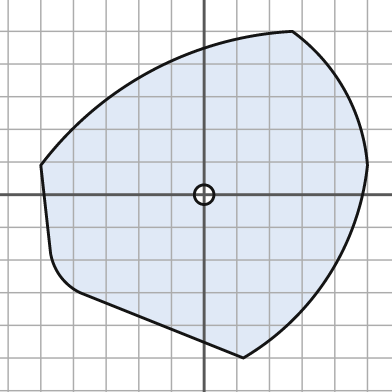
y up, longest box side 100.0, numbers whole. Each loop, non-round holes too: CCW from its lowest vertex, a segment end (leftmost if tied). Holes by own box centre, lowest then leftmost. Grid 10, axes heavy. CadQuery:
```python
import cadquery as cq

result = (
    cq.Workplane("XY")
    .moveTo(12.0, -50.0)
    .threePointArc((38.0, -25.0), (50.0, 9.0))
    .threePointArc((43.0, 32.0), (27.0, 50.0))
    .threePointArc((-16.0, 38.0), (-50.0, 9.0))
    .lineTo(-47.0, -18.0)
    .threePointArc((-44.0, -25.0), (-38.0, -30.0))
    .close()
    .moveTo(0.0, 0.0)
    .circle(3.0)
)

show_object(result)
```